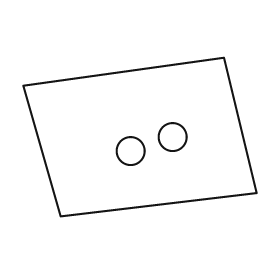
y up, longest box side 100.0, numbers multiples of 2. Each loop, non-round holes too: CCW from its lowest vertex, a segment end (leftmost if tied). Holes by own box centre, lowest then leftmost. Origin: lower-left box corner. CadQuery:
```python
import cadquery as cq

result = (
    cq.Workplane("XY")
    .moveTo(16.0, 0.0)
    .lineTo(100.0, 10.0)
    .lineTo(86.0, 68.0)
    .lineTo(0.0, 56.0)
    .close()
    .moveTo(46.0, 28.0)
    .circle(6.0)
    .moveTo(64.0, 34.0)
    .circle(6.0)
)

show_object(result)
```